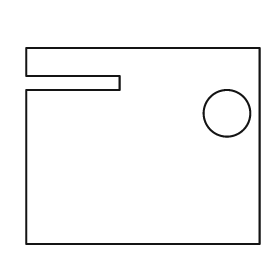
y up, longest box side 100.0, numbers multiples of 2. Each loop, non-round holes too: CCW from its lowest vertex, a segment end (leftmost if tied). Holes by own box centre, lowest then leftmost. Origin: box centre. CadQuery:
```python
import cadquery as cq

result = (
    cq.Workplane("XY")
    .moveTo(-50.0, -42.0)
    .lineTo(50.0, -42.0)
    .lineTo(50.0, 42.0)
    .lineTo(-50.0, 42.0)
    .lineTo(-50.0, 30.0)
    .lineTo(-10.0, 30.0)
    .lineTo(-10.0, 24.0)
    .lineTo(-50.0, 24.0)
    .close()
    .moveTo(36.0, 14.0)
    .circle(10.0)
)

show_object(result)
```